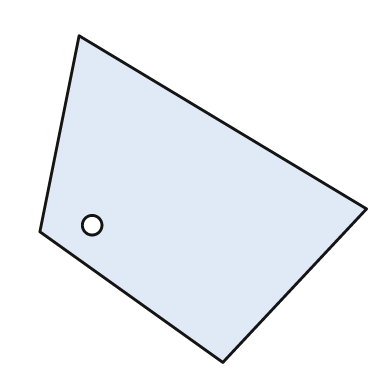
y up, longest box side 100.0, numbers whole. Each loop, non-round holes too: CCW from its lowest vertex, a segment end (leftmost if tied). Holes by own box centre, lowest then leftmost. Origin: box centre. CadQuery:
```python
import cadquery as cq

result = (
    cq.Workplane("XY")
    .moveTo(6.0, -50.0)
    .lineTo(50.0, -3.0)
    .lineTo(-38.0, 50.0)
    .lineTo(-50.0, -10.0)
    .close()
    .moveTo(-34.0, -8.0)
    .circle(3.0)
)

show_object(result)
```